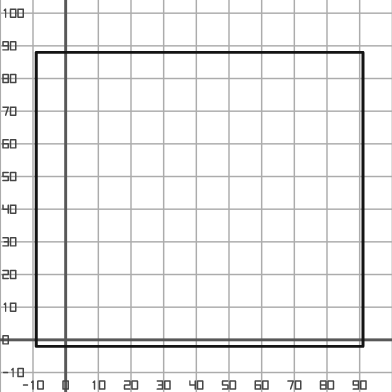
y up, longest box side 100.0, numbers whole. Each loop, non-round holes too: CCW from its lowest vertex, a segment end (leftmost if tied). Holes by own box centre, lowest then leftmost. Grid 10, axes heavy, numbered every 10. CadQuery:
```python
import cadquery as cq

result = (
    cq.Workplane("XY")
    .moveTo(-9.0, -2.0)
    .lineTo(91.0, -2.0)
    .lineTo(91.0, 88.0)
    .lineTo(-9.0, 88.0)
    .close()
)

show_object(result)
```